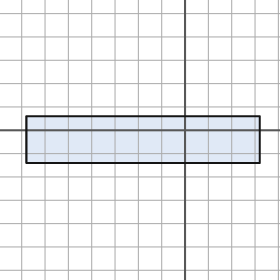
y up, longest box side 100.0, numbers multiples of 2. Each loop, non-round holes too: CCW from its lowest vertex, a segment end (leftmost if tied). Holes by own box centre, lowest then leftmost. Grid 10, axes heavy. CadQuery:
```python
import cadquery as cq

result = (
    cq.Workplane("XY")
    .moveTo(-68.0, -14.0)
    .lineTo(32.0, -14.0)
    .lineTo(32.0, 6.0)
    .lineTo(-68.0, 6.0)
    .close()
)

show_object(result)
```